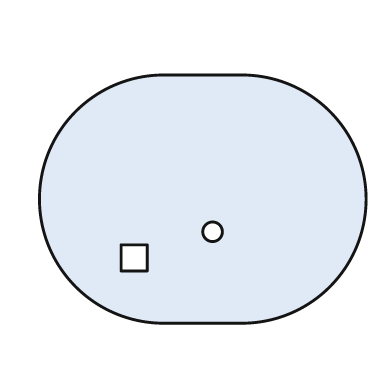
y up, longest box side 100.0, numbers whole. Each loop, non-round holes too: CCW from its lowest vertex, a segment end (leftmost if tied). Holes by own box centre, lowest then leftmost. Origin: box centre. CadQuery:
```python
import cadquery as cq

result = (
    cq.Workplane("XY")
    .moveTo(-12.0, -38.0)
    .lineTo(12.0, -38.0)
    .threePointArc((50.0, 0.0), (12.0, 38.0))
    .lineTo(-12.0, 38.0)
    .threePointArc((-50.0, 0.0), (-12.0, -38.0))
    .close()
    .moveTo(-25.0, -22.0)
    .lineTo(-17.0, -22.0)
    .lineTo(-17.0, -14.0)
    .lineTo(-25.0, -14.0)
    .close()
    .moveTo(3.0, -10.0)
    .circle(3.0)
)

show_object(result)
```